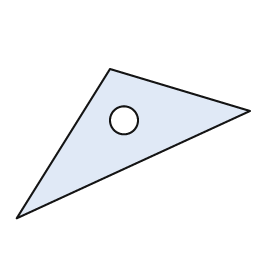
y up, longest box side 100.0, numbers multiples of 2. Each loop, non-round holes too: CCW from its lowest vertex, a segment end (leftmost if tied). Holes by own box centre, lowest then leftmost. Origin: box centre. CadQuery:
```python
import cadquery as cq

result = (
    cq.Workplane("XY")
    .moveTo(-50.0, -32.0)
    .lineTo(50.0, 14.0)
    .lineTo(-10.0, 32.0)
    .close()
    .moveTo(-4.0, 10.0)
    .circle(6.0)
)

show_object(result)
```